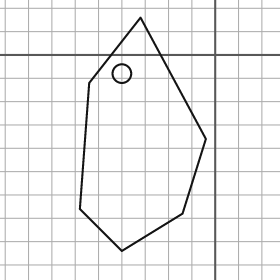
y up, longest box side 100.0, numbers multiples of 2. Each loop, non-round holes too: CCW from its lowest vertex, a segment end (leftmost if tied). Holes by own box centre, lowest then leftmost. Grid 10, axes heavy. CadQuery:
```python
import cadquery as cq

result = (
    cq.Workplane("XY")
    .moveTo(-40.0, -84.0)
    .lineTo(-14.0, -68.0)
    .lineTo(-4.0, -36.0)
    .lineTo(-32.0, 16.0)
    .lineTo(-54.0, -12.0)
    .lineTo(-58.0, -66.0)
    .close()
    .moveTo(-40.0, -8.0)
    .circle(4.0)
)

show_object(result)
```